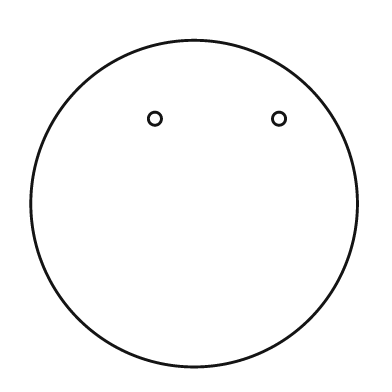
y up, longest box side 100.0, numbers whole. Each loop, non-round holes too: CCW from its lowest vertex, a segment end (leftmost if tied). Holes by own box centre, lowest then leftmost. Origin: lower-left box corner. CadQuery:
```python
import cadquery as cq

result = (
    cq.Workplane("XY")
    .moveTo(50.0, 50.0)
    .circle(50.0)
    .moveTo(38.0, 76.0)
    .circle(2.0)
    .moveTo(76.0, 76.0)
    .circle(2.0)
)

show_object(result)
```